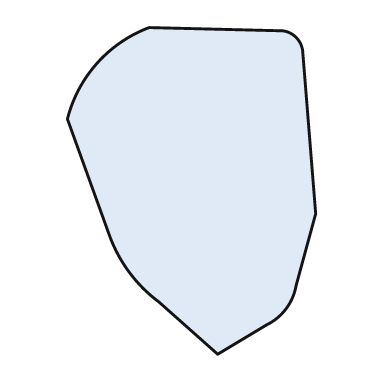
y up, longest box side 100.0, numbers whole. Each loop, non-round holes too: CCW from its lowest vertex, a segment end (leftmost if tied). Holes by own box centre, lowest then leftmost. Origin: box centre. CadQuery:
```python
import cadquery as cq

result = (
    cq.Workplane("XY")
    .moveTo(8.0, -50.0)
    .lineTo(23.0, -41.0)
    .threePointArc((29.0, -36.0), (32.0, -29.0))
    .lineTo(38.0, -7.0)
    .lineTo(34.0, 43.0)
    .threePointArc((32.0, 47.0), (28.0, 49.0))
    .lineTo(-13.0, 50.0)
    .threePointArc((-29.0, 39.0), (-38.0, 22.0))
    .lineTo(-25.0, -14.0)
    .threePointArc((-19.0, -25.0), (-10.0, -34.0))
    .close()
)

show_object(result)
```